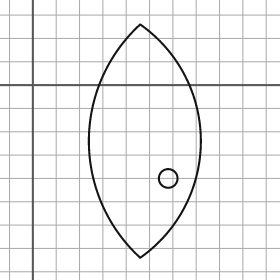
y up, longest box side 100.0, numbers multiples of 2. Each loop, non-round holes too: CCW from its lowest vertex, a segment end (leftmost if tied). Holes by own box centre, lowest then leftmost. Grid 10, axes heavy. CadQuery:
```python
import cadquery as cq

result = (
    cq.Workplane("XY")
    .moveTo(46.0, -74.0)
    .threePointArc((72.0, -24.0), (46.0, 26.0))
    .threePointArc((24.0, -24.0), (46.0, -74.0))
    .close()
    .moveTo(58.0, -40.0)
    .circle(4.0)
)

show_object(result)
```